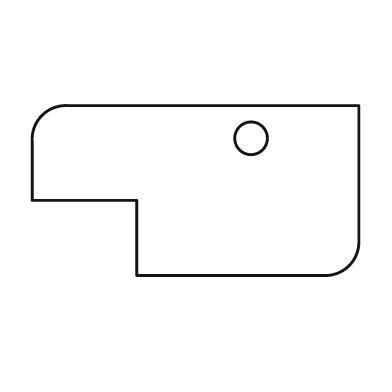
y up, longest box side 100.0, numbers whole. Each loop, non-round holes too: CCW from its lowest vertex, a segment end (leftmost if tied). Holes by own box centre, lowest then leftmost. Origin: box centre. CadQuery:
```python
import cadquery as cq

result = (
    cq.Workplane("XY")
    .moveTo(-18.0, -26.0)
    .lineTo(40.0, -26.0)
    .threePointArc((47.0, -23.0), (50.0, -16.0))
    .lineTo(50.0, 26.0)
    .lineTo(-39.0, 26.0)
    .threePointArc((-47.0, 23.0), (-50.0, 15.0))
    .lineTo(-50.0, -3.0)
    .lineTo(-18.0, -3.0)
    .close()
    .moveTo(17.0, 16.0)
    .circle(5.0)
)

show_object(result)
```